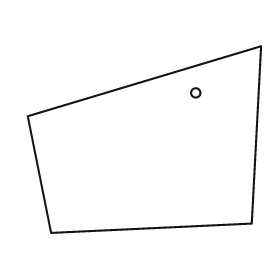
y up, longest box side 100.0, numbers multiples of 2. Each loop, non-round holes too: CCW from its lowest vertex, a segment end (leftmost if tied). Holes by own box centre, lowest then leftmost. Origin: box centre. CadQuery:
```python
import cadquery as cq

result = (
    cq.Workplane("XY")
    .moveTo(-40.0, -40.0)
    .lineTo(46.0, -36.0)
    .lineTo(50.0, 40.0)
    .lineTo(-50.0, 10.0)
    .close()
    .moveTo(22.0, 20.0)
    .circle(2.0)
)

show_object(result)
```